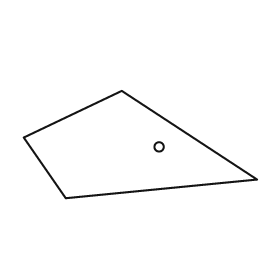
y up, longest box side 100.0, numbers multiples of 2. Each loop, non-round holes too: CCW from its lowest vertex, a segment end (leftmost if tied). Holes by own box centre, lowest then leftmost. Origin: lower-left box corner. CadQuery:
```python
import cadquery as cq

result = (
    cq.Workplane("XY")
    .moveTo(18.0, 0.0)
    .lineTo(100.0, 8.0)
    .lineTo(42.0, 46.0)
    .lineTo(0.0, 26.0)
    .close()
    .moveTo(58.0, 22.0)
    .circle(2.0)
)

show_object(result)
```